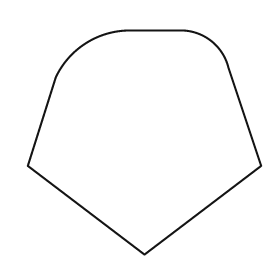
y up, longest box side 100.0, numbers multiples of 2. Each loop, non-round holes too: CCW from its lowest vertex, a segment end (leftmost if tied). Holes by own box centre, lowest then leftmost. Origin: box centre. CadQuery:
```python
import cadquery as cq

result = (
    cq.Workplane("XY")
    .moveTo(0.0, -48.0)
    .lineTo(50.0, -10.0)
    .lineTo(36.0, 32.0)
    .threePointArc((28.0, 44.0), (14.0, 48.0))
    .lineTo(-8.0, 48.0)
    .threePointArc((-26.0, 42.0), (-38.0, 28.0))
    .lineTo(-50.0, -10.0)
    .close()
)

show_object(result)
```